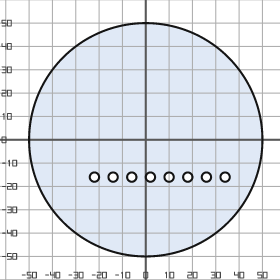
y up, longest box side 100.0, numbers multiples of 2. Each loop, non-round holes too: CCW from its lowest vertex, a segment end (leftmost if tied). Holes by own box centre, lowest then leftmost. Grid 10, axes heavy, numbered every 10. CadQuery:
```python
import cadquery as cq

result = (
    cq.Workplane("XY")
    .moveTo(0.0, 0.0)
    .circle(50.0)
    .moveTo(-22.0, -16.0)
    .circle(2.0)
    .moveTo(-14.0, -16.0)
    .circle(2.0)
    .moveTo(-6.0, -16.0)
    .circle(2.0)
    .moveTo(2.0, -16.0)
    .circle(2.0)
    .moveTo(10.0, -16.0)
    .circle(2.0)
    .moveTo(18.0, -16.0)
    .circle(2.0)
    .moveTo(26.0, -16.0)
    .circle(2.0)
    .moveTo(34.0, -16.0)
    .circle(2.0)
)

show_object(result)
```